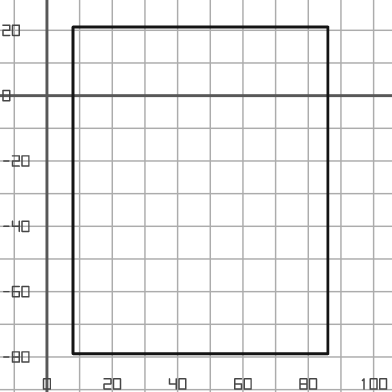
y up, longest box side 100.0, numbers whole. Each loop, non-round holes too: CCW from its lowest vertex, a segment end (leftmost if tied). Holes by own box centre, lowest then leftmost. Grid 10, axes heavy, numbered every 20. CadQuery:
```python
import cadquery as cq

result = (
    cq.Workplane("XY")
    .moveTo(8.0, -79.0)
    .lineTo(86.0, -79.0)
    .lineTo(86.0, 21.0)
    .lineTo(8.0, 21.0)
    .close()
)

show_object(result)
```